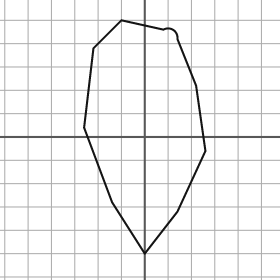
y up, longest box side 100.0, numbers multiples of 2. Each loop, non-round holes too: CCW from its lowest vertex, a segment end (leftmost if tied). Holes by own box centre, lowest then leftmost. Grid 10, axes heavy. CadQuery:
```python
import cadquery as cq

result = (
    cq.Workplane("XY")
    .moveTo(0.0, -50.0)
    .lineTo(14.0, -32.0)
    .lineTo(26.0, -6.0)
    .lineTo(22.0, 22.0)
    .lineTo(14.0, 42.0)
    .threePointArc((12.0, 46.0), (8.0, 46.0))
    .lineTo(-10.0, 50.0)
    .lineTo(-22.0, 38.0)
    .lineTo(-26.0, 4.0)
    .lineTo(-14.0, -28.0)
    .close()
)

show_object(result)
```